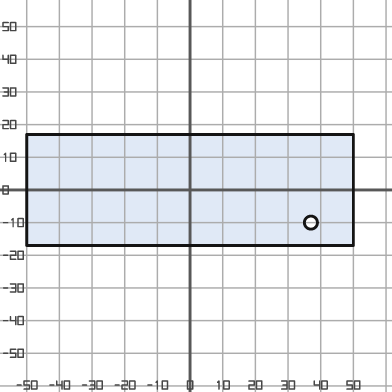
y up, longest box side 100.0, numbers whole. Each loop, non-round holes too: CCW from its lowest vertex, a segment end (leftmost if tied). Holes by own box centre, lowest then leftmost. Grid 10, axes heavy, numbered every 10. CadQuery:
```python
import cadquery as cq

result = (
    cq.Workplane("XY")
    .moveTo(-50.0, -17.0)
    .lineTo(50.0, -17.0)
    .lineTo(50.0, 17.0)
    .lineTo(-50.0, 17.0)
    .close()
    .moveTo(37.0, -10.0)
    .circle(2.0)
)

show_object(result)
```